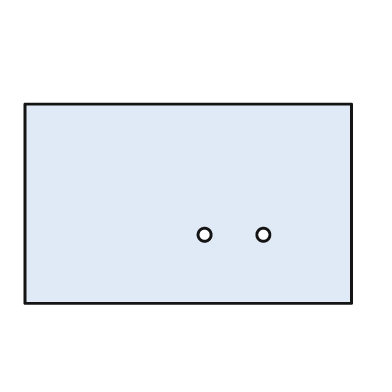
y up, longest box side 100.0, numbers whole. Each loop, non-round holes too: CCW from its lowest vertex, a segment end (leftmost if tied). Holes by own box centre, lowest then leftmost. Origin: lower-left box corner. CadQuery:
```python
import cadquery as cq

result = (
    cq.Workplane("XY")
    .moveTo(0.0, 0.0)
    .lineTo(100.0, 0.0)
    .lineTo(100.0, 61.0)
    .lineTo(0.0, 61.0)
    .close()
    .moveTo(55.0, 21.0)
    .circle(2.0)
    .moveTo(73.0, 21.0)
    .circle(2.0)
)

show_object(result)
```